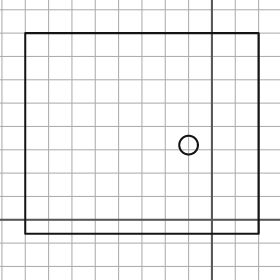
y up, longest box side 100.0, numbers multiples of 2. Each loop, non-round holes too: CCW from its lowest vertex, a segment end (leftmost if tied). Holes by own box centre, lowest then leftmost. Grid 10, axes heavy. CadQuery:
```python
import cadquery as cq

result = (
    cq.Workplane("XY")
    .moveTo(-80.0, -6.0)
    .lineTo(20.0, -6.0)
    .lineTo(20.0, 80.0)
    .lineTo(-80.0, 80.0)
    .close()
    .moveTo(-10.0, 32.0)
    .circle(4.0)
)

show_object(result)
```